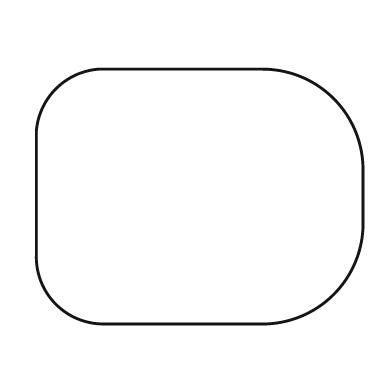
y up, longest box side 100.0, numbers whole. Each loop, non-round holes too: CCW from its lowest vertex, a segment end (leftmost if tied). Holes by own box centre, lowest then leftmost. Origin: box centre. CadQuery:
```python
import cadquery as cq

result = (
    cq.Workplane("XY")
    .moveTo(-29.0, -39.0)
    .lineTo(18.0, -39.0)
    .threePointArc((41.0, -30.0), (50.0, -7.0))
    .lineTo(50.0, 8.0)
    .threePointArc((41.0, 30.0), (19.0, 39.0))
    .lineTo(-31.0, 39.0)
    .threePointArc((-44.0, 33.0), (-50.0, 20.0))
    .lineTo(-50.0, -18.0)
    .threePointArc((-44.0, -33.0), (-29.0, -39.0))
    .close()
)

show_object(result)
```